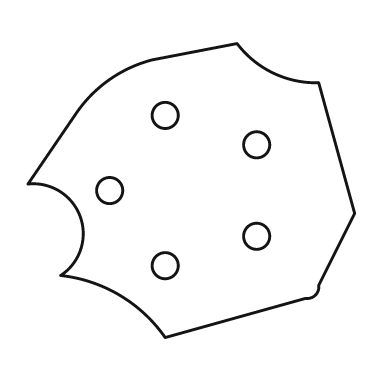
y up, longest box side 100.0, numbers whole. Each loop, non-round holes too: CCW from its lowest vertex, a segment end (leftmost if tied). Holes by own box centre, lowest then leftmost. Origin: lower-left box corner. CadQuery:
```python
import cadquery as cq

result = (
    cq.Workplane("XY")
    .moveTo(42.0, 0.0)
    .lineTo(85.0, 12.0)
    .threePointArc((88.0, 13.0), (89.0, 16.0))
    .lineTo(100.0, 38.0)
    .lineTo(89.0, 78.0)
    .threePointArc((75.0, 81.0), (64.0, 90.0))
    .lineTo(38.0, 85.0)
    .threePointArc((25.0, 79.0), (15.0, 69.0))
    .lineTo(0.0, 47.0)
    .threePointArc((16.0, 37.0), (10.0, 19.0))
    .threePointArc((28.0, 13.0), (42.0, 0.0))
    .close()
    .moveTo(42.0, 22.0)
    .circle(4.0)
    .moveTo(70.0, 31.0)
    .circle(4.0)
    .moveTo(25.0, 45.0)
    .circle(4.0)
    .moveTo(70.0, 59.0)
    .circle(4.0)
    .moveTo(42.0, 68.0)
    .circle(4.0)
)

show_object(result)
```